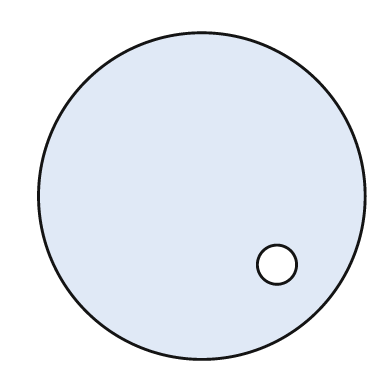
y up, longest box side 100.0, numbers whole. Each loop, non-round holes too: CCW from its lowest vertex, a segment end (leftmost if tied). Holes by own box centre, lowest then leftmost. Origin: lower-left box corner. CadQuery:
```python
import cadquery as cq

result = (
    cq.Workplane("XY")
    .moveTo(50.0, 50.0)
    .circle(50.0)
    .moveTo(73.0, 29.0)
    .circle(6.0)
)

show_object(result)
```